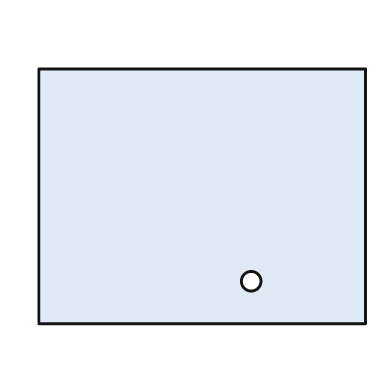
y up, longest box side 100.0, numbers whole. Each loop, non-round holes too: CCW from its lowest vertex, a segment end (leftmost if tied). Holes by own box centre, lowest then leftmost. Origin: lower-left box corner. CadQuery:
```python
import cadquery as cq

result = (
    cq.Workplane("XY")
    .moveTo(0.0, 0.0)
    .lineTo(100.0, 0.0)
    .lineTo(100.0, 78.0)
    .lineTo(0.0, 78.0)
    .close()
    .moveTo(65.0, 13.0)
    .circle(3.0)
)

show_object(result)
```